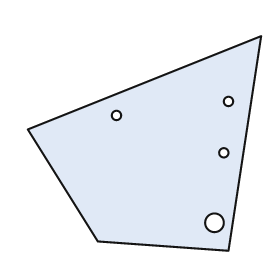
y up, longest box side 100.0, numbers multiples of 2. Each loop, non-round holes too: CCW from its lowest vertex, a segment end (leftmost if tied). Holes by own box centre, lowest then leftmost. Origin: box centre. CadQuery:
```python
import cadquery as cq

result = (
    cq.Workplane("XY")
    .moveTo(36.0, -46.0)
    .lineTo(50.0, 46.0)
    .lineTo(-50.0, 6.0)
    .lineTo(-20.0, -42.0)
    .close()
    .moveTo(30.0, -34.0)
    .circle(4.0)
    .moveTo(34.0, -4.0)
    .circle(2.0)
    .moveTo(-12.0, 12.0)
    .circle(2.0)
    .moveTo(36.0, 18.0)
    .circle(2.0)
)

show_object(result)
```